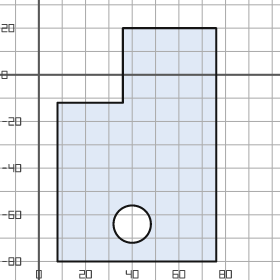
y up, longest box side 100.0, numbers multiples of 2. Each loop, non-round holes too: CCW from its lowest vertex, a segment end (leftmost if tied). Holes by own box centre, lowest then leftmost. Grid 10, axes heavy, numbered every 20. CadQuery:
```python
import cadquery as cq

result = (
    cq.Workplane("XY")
    .moveTo(8.0, -80.0)
    .lineTo(76.0, -80.0)
    .lineTo(76.0, 20.0)
    .lineTo(36.0, 20.0)
    .lineTo(36.0, -12.0)
    .lineTo(8.0, -12.0)
    .close()
    .moveTo(40.0, -64.0)
    .circle(8.0)
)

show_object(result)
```